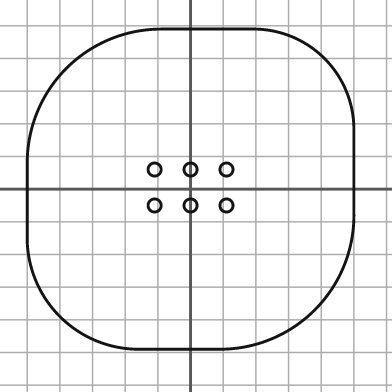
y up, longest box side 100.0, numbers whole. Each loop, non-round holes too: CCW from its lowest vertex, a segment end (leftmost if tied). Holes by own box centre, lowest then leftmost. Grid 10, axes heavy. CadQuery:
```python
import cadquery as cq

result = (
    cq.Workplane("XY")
    .moveTo(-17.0, -49.0)
    .lineTo(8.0, -49.0)
    .threePointArc((38.0, -37.0), (50.0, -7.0))
    .lineTo(50.0, 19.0)
    .threePointArc((41.0, 40.0), (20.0, 49.0))
    .lineTo(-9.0, 49.0)
    .threePointArc((-38.0, 37.0), (-50.0, 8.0))
    .lineTo(-50.0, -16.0)
    .threePointArc((-40.0, -39.0), (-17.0, -49.0))
    .close()
    .moveTo(-11.0, -5.0)
    .circle(2.0)
    .moveTo(0.0, -5.0)
    .circle(2.0)
    .moveTo(11.0, -5.0)
    .circle(2.0)
    .moveTo(-11.0, 6.0)
    .circle(2.0)
    .moveTo(0.0, 6.0)
    .circle(2.0)
    .moveTo(11.0, 6.0)
    .circle(2.0)
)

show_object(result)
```